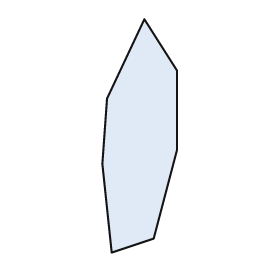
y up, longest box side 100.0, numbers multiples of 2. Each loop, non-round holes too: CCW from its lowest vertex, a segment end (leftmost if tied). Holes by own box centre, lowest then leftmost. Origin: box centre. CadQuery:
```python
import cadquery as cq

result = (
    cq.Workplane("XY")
    .moveTo(-12.0, -50.0)
    .lineTo(6.0, -44.0)
    .lineTo(16.0, -6.0)
    .lineTo(16.0, 28.0)
    .lineTo(2.0, 50.0)
    .lineTo(-14.0, 16.0)
    .lineTo(-16.0, -12.0)
    .close()
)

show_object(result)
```